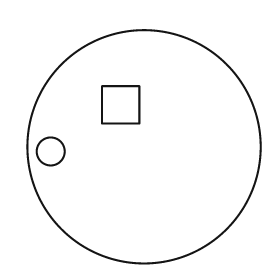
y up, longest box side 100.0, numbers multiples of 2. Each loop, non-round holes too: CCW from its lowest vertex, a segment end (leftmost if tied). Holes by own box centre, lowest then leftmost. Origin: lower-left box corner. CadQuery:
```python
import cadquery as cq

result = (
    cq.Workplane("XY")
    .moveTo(50.0, 50.0)
    .circle(50.0)
    .moveTo(10.0, 48.0)
    .circle(6.0)
    .moveTo(32.0, 60.0)
    .lineTo(48.0, 60.0)
    .lineTo(48.0, 76.0)
    .lineTo(32.0, 76.0)
    .close()
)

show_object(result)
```